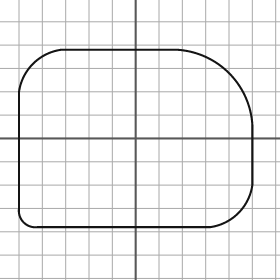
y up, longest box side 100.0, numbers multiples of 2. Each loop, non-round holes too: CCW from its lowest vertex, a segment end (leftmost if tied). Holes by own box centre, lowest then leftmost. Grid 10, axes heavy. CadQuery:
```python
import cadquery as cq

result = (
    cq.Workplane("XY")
    .moveTo(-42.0, -38.0)
    .lineTo(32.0, -38.0)
    .threePointArc((44.0, -32.0), (50.0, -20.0))
    .lineTo(50.0, 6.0)
    .threePointArc((40.0, 28.0), (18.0, 38.0))
    .lineTo(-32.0, 38.0)
    .threePointArc((-44.0, 32.0), (-50.0, 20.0))
    .lineTo(-50.0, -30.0)
    .threePointArc((-48.0, -36.0), (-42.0, -38.0))
    .close()
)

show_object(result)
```